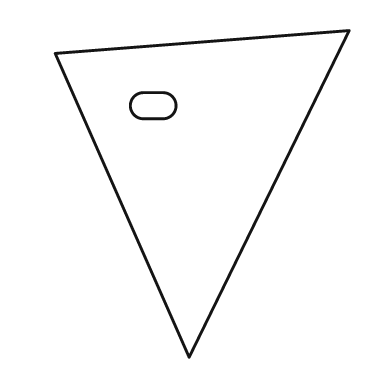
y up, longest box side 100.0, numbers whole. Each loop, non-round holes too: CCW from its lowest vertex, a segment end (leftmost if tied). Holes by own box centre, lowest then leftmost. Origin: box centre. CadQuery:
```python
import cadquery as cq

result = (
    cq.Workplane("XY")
    .moveTo(-4.0, -50.0)
    .lineTo(45.0, 50.0)
    .lineTo(-45.0, 43.0)
    .close()
    .moveTo(-18.0, 23.0)
    .lineTo(-12.0, 23.0)
    .threePointArc((-8.0, 27.0), (-12.0, 31.0))
    .lineTo(-18.0, 31.0)
    .threePointArc((-22.0, 27.0), (-18.0, 23.0))
    .close()
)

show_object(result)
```